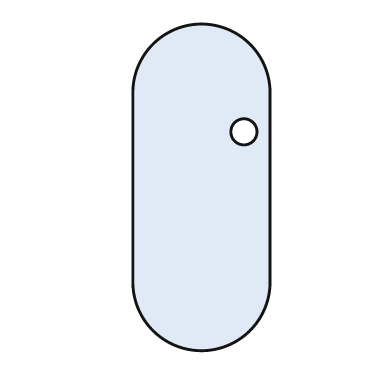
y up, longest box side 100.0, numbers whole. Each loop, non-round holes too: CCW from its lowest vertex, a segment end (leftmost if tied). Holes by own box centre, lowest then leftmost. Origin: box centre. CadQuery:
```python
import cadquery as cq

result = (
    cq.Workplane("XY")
    .moveTo(-21.0, -29.0)
    .threePointArc((0.0, -50.0), (21.0, -29.0))
    .lineTo(21.0, 29.0)
    .threePointArc((0.0, 50.0), (-21.0, 29.0))
    .close()
    .moveTo(13.0, 17.0)
    .circle(4.0)
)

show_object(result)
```